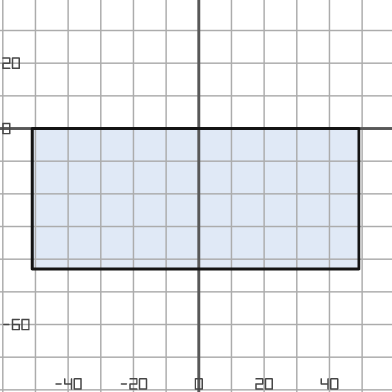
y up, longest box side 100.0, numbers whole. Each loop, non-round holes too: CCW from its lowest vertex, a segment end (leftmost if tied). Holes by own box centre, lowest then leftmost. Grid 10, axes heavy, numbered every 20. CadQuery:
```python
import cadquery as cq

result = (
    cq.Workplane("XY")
    .moveTo(-51.0, -43.0)
    .lineTo(49.0, -43.0)
    .lineTo(49.0, 0.0)
    .lineTo(-51.0, 0.0)
    .close()
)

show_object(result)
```